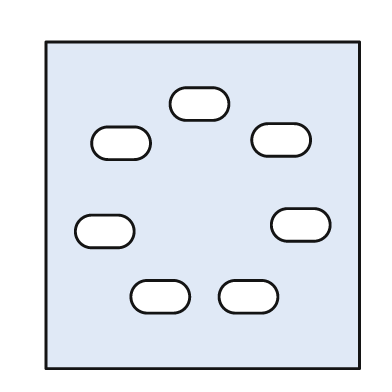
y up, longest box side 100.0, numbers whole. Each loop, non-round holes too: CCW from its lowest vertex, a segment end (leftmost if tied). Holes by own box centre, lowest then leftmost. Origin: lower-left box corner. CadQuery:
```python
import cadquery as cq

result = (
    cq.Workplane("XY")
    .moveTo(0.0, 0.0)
    .lineTo(96.0, 0.0)
    .lineTo(96.0, 100.0)
    .lineTo(0.0, 100.0)
    .close()
    .moveTo(31.0, 17.0)
    .lineTo(39.0, 17.0)
    .threePointArc((44.0, 22.0), (39.0, 27.0))
    .lineTo(31.0, 27.0)
    .threePointArc((26.0, 22.0), (31.0, 17.0))
    .close()
    .moveTo(58.0, 17.0)
    .lineTo(66.0, 17.0)
    .threePointArc((71.0, 22.0), (66.0, 27.0))
    .lineTo(58.0, 27.0)
    .threePointArc((53.0, 22.0), (58.0, 17.0))
    .close()
    .moveTo(14.0, 37.0)
    .lineTo(22.0, 37.0)
    .threePointArc((27.0, 42.0), (22.0, 47.0))
    .lineTo(14.0, 47.0)
    .threePointArc((9.0, 42.0), (14.0, 37.0))
    .close()
    .moveTo(74.0, 39.0)
    .lineTo(82.0, 39.0)
    .threePointArc((87.0, 44.0), (82.0, 49.0))
    .lineTo(74.0, 49.0)
    .threePointArc((69.0, 44.0), (74.0, 39.0))
    .close()
    .moveTo(19.0, 64.0)
    .lineTo(27.0, 64.0)
    .threePointArc((32.0, 69.0), (27.0, 74.0))
    .lineTo(19.0, 74.0)
    .threePointArc((14.0, 69.0), (19.0, 64.0))
    .close()
    .moveTo(68.0, 65.0)
    .lineTo(76.0, 65.0)
    .threePointArc((81.0, 70.0), (76.0, 75.0))
    .lineTo(68.0, 75.0)
    .threePointArc((63.0, 70.0), (68.0, 65.0))
    .close()
    .moveTo(43.0, 76.0)
    .lineTo(51.0, 76.0)
    .threePointArc((56.0, 81.0), (51.0, 86.0))
    .lineTo(43.0, 86.0)
    .threePointArc((38.0, 81.0), (43.0, 76.0))
    .close()
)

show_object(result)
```